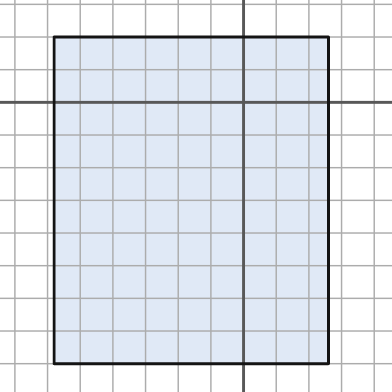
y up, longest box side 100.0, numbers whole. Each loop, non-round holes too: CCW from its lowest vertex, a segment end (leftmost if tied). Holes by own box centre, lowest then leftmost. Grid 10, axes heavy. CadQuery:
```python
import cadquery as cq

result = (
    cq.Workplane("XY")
    .moveTo(-58.0, -80.0)
    .lineTo(26.0, -80.0)
    .lineTo(26.0, 20.0)
    .lineTo(-58.0, 20.0)
    .close()
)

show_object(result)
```